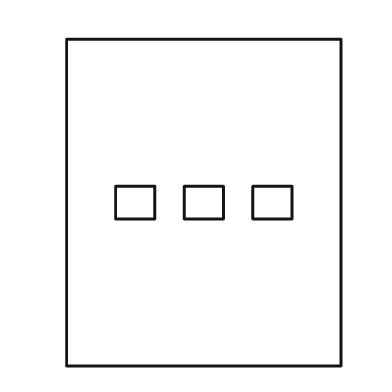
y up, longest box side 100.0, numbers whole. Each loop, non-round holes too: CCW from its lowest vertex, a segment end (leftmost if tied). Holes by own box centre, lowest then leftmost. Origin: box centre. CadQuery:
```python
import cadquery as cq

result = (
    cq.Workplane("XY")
    .moveTo(-42.0, -50.0)
    .lineTo(42.0, -50.0)
    .lineTo(42.0, 50.0)
    .lineTo(-42.0, 50.0)
    .close()
    .moveTo(-27.0, -5.0)
    .lineTo(-15.0, -5.0)
    .lineTo(-15.0, 5.0)
    .lineTo(-27.0, 5.0)
    .close()
    .moveTo(-6.0, -5.0)
    .lineTo(6.0, -5.0)
    .lineTo(6.0, 5.0)
    .lineTo(-6.0, 5.0)
    .close()
    .moveTo(15.0, -5.0)
    .lineTo(27.0, -5.0)
    .lineTo(27.0, 5.0)
    .lineTo(15.0, 5.0)
    .close()
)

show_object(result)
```